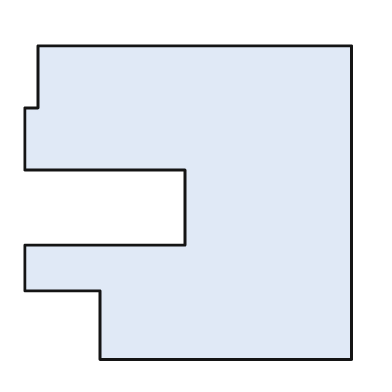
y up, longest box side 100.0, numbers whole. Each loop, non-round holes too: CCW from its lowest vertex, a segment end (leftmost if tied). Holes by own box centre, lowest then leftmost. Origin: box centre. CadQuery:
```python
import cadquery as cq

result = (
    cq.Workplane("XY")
    .moveTo(-27.0, -48.0)
    .lineTo(50.0, -48.0)
    .lineTo(50.0, 48.0)
    .lineTo(-46.0, 48.0)
    .lineTo(-46.0, 29.0)
    .lineTo(-50.0, 29.0)
    .lineTo(-50.0, 10.0)
    .lineTo(-1.0, 10.0)
    .lineTo(-1.0, -13.0)
    .lineTo(-50.0, -13.0)
    .lineTo(-50.0, -27.0)
    .lineTo(-27.0, -27.0)
    .close()
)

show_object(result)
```